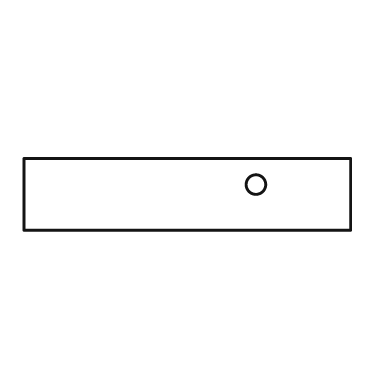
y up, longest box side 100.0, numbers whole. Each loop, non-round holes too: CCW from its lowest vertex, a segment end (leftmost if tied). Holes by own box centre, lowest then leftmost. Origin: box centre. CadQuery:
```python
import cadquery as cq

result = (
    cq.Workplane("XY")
    .moveTo(-50.0, -11.0)
    .lineTo(50.0, -11.0)
    .lineTo(50.0, 11.0)
    .lineTo(-50.0, 11.0)
    .close()
    .moveTo(21.0, 3.0)
    .circle(3.0)
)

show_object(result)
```